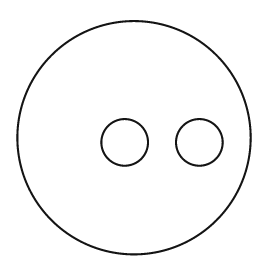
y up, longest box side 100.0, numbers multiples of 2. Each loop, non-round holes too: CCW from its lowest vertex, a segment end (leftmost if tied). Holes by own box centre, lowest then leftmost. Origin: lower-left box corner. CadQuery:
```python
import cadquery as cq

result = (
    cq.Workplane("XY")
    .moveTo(50.0, 50.0)
    .circle(50.0)
    .moveTo(46.0, 48.0)
    .circle(10.0)
    .moveTo(78.0, 48.0)
    .circle(10.0)
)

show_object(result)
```